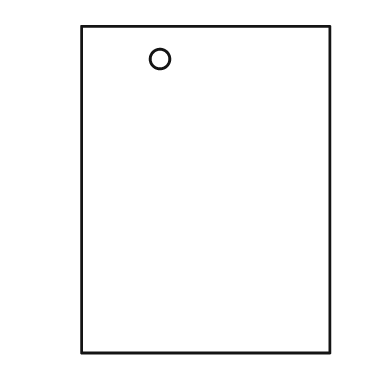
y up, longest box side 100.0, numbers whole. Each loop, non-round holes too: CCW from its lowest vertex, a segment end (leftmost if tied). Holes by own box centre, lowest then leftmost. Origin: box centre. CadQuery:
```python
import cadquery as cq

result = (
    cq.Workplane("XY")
    .moveTo(-38.0, -50.0)
    .lineTo(38.0, -50.0)
    .lineTo(38.0, 50.0)
    .lineTo(-38.0, 50.0)
    .close()
    .moveTo(-14.0, 40.0)
    .circle(3.0)
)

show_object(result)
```